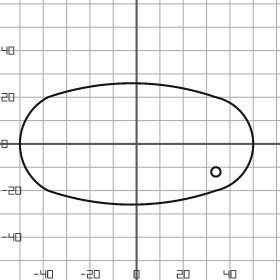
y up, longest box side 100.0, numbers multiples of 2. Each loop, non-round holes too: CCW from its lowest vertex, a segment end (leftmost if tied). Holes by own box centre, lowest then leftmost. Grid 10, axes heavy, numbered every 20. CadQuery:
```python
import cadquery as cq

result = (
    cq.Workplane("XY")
    .moveTo(-38.0, -20.0)
    .threePointArc((-2.0, -26.0), (34.0, -20.0))
    .threePointArc((50.0, 0.0), (34.0, 20.0))
    .threePointArc((-2.0, 26.0), (-38.0, 20.0))
    .threePointArc((-50.0, 0.0), (-38.0, -20.0))
    .close()
    .moveTo(34.0, -12.0)
    .circle(2.0)
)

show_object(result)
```